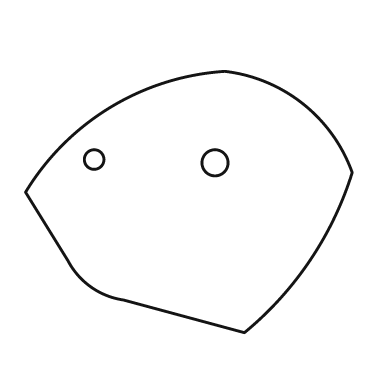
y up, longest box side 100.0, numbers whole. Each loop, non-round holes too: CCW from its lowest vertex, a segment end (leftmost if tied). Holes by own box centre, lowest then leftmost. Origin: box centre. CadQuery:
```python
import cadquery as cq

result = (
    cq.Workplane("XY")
    .moveTo(17.0, -40.0)
    .threePointArc((37.0, -18.0), (50.0, 9.0))
    .threePointArc((35.0, 30.0), (11.0, 40.0))
    .threePointArc((-24.0, 29.0), (-50.0, 3.0))
    .lineTo(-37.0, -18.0)
    .threePointArc((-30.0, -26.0), (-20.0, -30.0))
    .close()
    .moveTo(8.0, 12.0)
    .circle(4.0)
    .moveTo(-29.0, 13.0)
    .circle(3.0)
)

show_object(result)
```